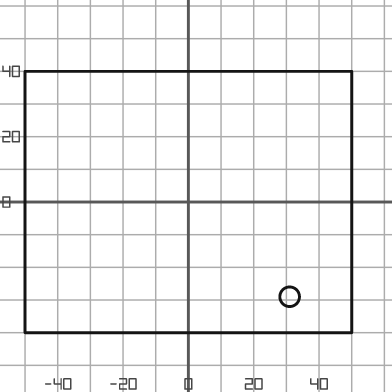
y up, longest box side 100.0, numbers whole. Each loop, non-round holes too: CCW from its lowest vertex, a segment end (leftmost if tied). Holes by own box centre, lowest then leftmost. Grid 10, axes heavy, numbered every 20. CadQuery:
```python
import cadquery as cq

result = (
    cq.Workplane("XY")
    .moveTo(-50.0, -40.0)
    .lineTo(50.0, -40.0)
    .lineTo(50.0, 40.0)
    .lineTo(-50.0, 40.0)
    .close()
    .moveTo(31.0, -29.0)
    .circle(3.0)
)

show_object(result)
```